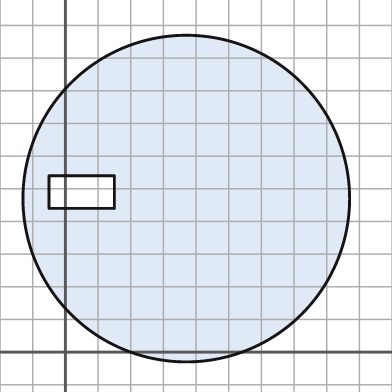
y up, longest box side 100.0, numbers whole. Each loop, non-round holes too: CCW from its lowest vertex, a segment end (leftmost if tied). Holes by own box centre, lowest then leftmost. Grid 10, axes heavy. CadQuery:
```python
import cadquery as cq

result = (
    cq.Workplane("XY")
    .moveTo(37.0, 47.0)
    .circle(50.0)
    .moveTo(-5.0, 44.0)
    .lineTo(15.0, 44.0)
    .lineTo(15.0, 54.0)
    .lineTo(-5.0, 54.0)
    .close()
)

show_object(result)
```